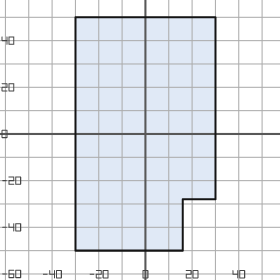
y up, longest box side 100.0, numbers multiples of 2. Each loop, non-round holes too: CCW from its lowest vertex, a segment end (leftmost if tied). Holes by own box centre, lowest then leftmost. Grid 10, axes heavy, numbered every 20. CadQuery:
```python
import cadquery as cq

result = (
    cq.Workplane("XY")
    .moveTo(-30.0, -50.0)
    .lineTo(16.0, -50.0)
    .lineTo(16.0, -28.0)
    .lineTo(30.0, -28.0)
    .lineTo(30.0, 50.0)
    .lineTo(-30.0, 50.0)
    .close()
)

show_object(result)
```